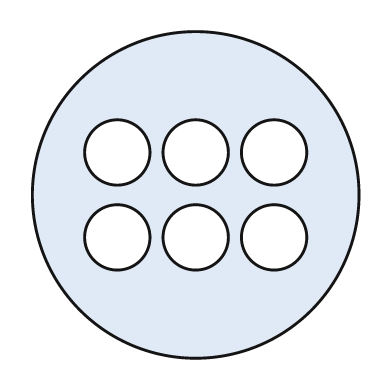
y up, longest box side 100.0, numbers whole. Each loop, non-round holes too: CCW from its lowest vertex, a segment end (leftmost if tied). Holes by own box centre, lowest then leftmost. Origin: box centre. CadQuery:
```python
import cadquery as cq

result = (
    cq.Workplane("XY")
    .moveTo(0.0, 0.0)
    .circle(50.0)
    .moveTo(-24.0, -13.0)
    .circle(10.0)
    .moveTo(0.0, -13.0)
    .circle(10.0)
    .moveTo(24.0, -13.0)
    .circle(10.0)
    .moveTo(-24.0, 13.0)
    .circle(10.0)
    .moveTo(0.0, 13.0)
    .circle(10.0)
    .moveTo(24.0, 13.0)
    .circle(10.0)
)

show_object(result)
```